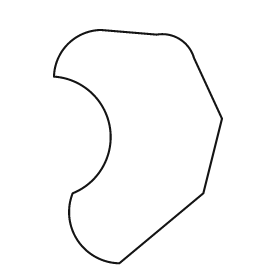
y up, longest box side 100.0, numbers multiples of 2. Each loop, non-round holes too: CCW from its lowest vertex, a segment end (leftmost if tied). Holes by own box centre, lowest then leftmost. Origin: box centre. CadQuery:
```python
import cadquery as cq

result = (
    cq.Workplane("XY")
    .moveTo(-8.0, -50.0)
    .lineTo(28.0, -20.0)
    .lineTo(36.0, 12.0)
    .lineTo(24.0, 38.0)
    .threePointArc((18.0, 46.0), (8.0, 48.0))
    .lineTo(-16.0, 50.0)
    .threePointArc((-30.0, 44.0), (-36.0, 30.0))
    .threePointArc((-12.0, 8.0), (-28.0, -20.0))
    .threePointArc((-26.0, -40.0), (-8.0, -50.0))
    .close()
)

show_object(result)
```